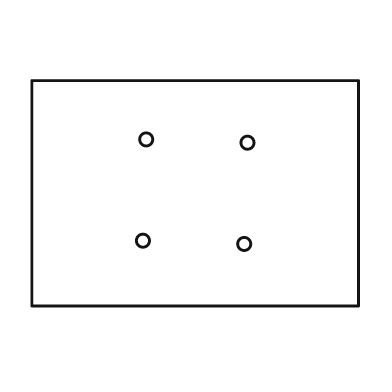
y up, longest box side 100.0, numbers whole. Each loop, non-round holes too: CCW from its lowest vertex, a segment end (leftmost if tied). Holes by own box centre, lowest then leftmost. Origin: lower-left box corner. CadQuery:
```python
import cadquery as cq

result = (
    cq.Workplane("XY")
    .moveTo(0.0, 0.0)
    .lineTo(100.0, 0.0)
    .lineTo(100.0, 69.0)
    .lineTo(0.0, 69.0)
    .close()
    .moveTo(65.0, 19.0)
    .circle(2.0)
    .moveTo(34.0, 20.0)
    .circle(2.0)
    .moveTo(66.0, 50.0)
    .circle(2.0)
    .moveTo(35.0, 51.0)
    .circle(2.0)
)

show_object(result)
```